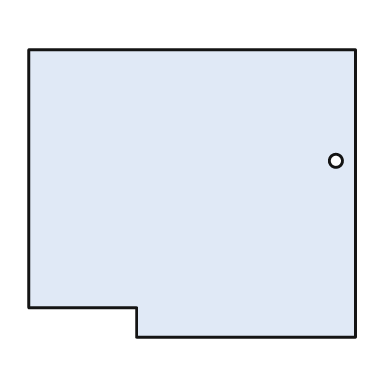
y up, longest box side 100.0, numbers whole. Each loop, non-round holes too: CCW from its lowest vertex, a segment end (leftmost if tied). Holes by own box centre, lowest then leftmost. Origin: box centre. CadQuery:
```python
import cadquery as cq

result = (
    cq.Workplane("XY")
    .moveTo(-17.0, -44.0)
    .lineTo(50.0, -44.0)
    .lineTo(50.0, 44.0)
    .lineTo(-50.0, 44.0)
    .lineTo(-50.0, -35.0)
    .lineTo(-17.0, -35.0)
    .close()
    .moveTo(44.0, 10.0)
    .circle(2.0)
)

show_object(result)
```